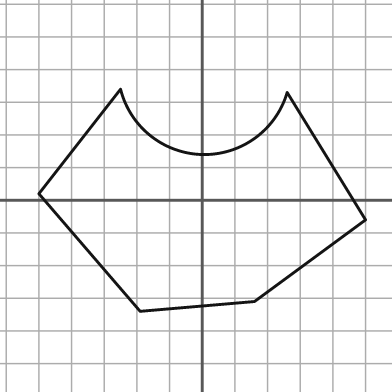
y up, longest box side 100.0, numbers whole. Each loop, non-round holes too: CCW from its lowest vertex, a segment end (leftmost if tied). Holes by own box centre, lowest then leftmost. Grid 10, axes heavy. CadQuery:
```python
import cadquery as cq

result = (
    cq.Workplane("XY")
    .moveTo(-19.0, -34.0)
    .lineTo(16.0, -31.0)
    .lineTo(50.0, -6.0)
    .lineTo(26.0, 33.0)
    .threePointArc((0.0, 14.0), (-25.0, 34.0))
    .lineTo(-50.0, 2.0)
    .close()
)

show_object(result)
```